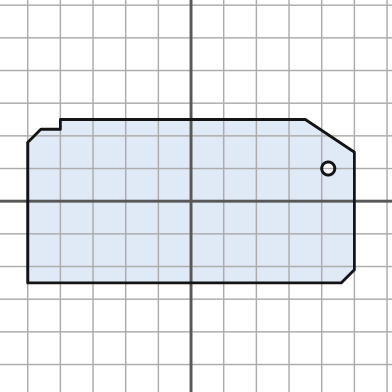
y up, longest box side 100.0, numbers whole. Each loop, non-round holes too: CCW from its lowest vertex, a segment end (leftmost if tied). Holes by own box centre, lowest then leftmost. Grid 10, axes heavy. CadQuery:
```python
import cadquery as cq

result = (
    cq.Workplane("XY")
    .moveTo(-50.0, -25.0)
    .lineTo(46.0, -25.0)
    .lineTo(50.0, -21.0)
    .lineTo(50.0, 15.0)
    .lineTo(35.0, 25.0)
    .lineTo(-40.0, 25.0)
    .lineTo(-40.0, 22.0)
    .lineTo(-46.0, 22.0)
    .lineTo(-50.0, 18.0)
    .close()
    .moveTo(42.0, 10.0)
    .circle(2.0)
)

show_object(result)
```